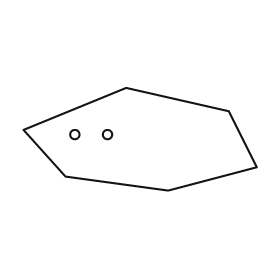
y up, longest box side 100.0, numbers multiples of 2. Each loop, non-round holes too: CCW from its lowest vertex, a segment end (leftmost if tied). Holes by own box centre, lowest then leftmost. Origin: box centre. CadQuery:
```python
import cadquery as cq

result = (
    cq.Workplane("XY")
    .moveTo(12.0, -22.0)
    .lineTo(50.0, -12.0)
    .lineTo(38.0, 12.0)
    .lineTo(-6.0, 22.0)
    .lineTo(-50.0, 4.0)
    .lineTo(-32.0, -16.0)
    .close()
    .moveTo(-28.0, 2.0)
    .circle(2.0)
    .moveTo(-14.0, 2.0)
    .circle(2.0)
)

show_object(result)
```